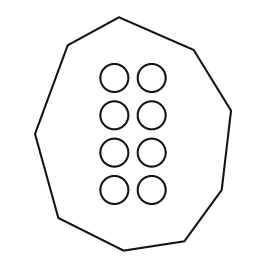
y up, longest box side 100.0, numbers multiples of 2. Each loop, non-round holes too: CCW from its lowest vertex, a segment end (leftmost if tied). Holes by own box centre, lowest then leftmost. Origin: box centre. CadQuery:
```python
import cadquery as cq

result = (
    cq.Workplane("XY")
    .moveTo(-4.0, -50.0)
    .lineTo(22.0, -46.0)
    .lineTo(38.0, -24.0)
    .lineTo(42.0, 10.0)
    .lineTo(26.0, 36.0)
    .lineTo(-6.0, 50.0)
    .lineTo(-28.0, 38.0)
    .lineTo(-42.0, 0.0)
    .lineTo(-32.0, -36.0)
    .close()
    .moveTo(-8.0, -24.0)
    .circle(6.0)
    .moveTo(8.0, -24.0)
    .circle(6.0)
    .moveTo(-8.0, -8.0)
    .circle(6.0)
    .moveTo(8.0, -8.0)
    .circle(6.0)
    .moveTo(-8.0, 8.0)
    .circle(6.0)
    .moveTo(8.0, 8.0)
    .circle(6.0)
    .moveTo(-8.0, 24.0)
    .circle(6.0)
    .moveTo(8.0, 24.0)
    .circle(6.0)
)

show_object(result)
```